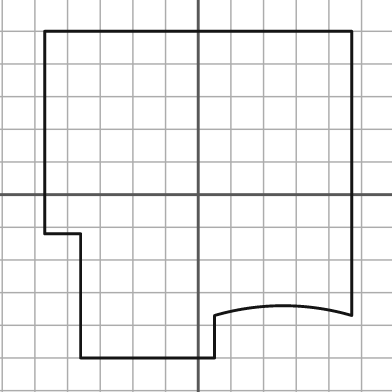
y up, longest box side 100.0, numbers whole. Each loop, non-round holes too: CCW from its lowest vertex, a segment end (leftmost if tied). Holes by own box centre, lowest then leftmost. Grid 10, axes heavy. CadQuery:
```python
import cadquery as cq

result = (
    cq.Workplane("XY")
    .moveTo(-36.0, -50.0)
    .lineTo(5.0, -50.0)
    .lineTo(5.0, -37.0)
    .threePointArc((26.0, -34.0), (47.0, -37.0))
    .lineTo(47.0, 50.0)
    .lineTo(-47.0, 50.0)
    .lineTo(-47.0, -12.0)
    .lineTo(-36.0, -12.0)
    .close()
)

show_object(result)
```